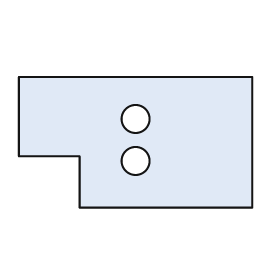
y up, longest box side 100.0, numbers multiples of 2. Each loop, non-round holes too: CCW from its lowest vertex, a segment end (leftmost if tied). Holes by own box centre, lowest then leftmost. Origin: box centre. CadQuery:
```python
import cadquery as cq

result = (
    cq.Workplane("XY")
    .moveTo(-24.0, -28.0)
    .lineTo(50.0, -28.0)
    .lineTo(50.0, 28.0)
    .lineTo(-50.0, 28.0)
    .lineTo(-50.0, -6.0)
    .lineTo(-24.0, -6.0)
    .close()
    .moveTo(0.0, -8.0)
    .circle(6.0)
    .moveTo(0.0, 10.0)
    .circle(6.0)
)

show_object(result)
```